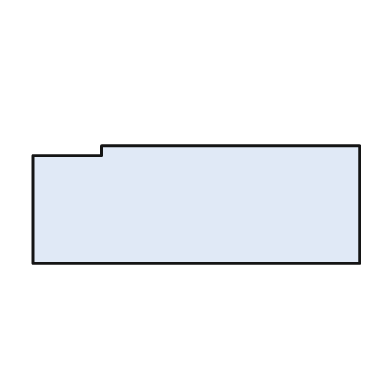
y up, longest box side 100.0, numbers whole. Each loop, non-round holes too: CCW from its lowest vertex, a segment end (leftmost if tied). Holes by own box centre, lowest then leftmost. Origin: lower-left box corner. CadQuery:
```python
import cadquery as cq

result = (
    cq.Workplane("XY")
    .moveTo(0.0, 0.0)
    .lineTo(100.0, 0.0)
    .lineTo(100.0, 36.0)
    .lineTo(21.0, 36.0)
    .lineTo(21.0, 33.0)
    .lineTo(0.0, 33.0)
    .close()
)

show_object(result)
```